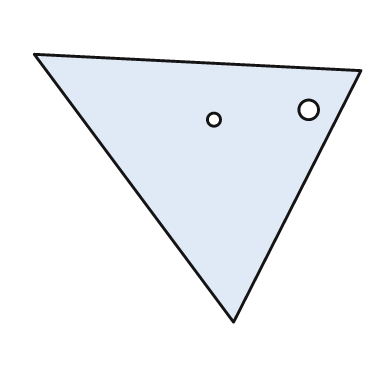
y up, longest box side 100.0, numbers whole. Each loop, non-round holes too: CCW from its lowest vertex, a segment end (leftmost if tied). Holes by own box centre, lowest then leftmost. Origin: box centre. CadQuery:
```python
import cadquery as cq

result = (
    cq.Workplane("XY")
    .moveTo(11.0, -41.0)
    .lineTo(50.0, 36.0)
    .lineTo(-50.0, 41.0)
    .close()
    .moveTo(5.0, 21.0)
    .circle(2.0)
    .moveTo(34.0, 24.0)
    .circle(3.0)
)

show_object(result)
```